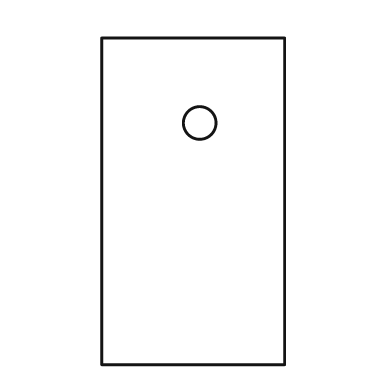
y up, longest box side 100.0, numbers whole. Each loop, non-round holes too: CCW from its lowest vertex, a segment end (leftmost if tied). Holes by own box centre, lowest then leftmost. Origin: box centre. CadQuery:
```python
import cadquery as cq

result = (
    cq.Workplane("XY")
    .moveTo(-28.0, -50.0)
    .lineTo(28.0, -50.0)
    .lineTo(28.0, 50.0)
    .lineTo(-28.0, 50.0)
    .close()
    .moveTo(2.0, 24.0)
    .circle(5.0)
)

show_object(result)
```